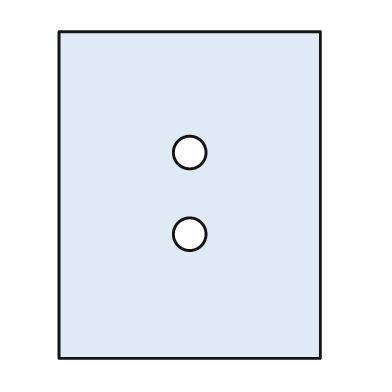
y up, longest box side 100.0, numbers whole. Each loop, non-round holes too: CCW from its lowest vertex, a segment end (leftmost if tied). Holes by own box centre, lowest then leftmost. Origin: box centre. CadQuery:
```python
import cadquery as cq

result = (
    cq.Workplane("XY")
    .moveTo(-40.0, -50.0)
    .lineTo(40.0, -50.0)
    .lineTo(40.0, 50.0)
    .lineTo(-40.0, 50.0)
    .close()
    .moveTo(0.0, -12.0)
    .circle(5.0)
    .moveTo(0.0, 13.0)
    .circle(5.0)
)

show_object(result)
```